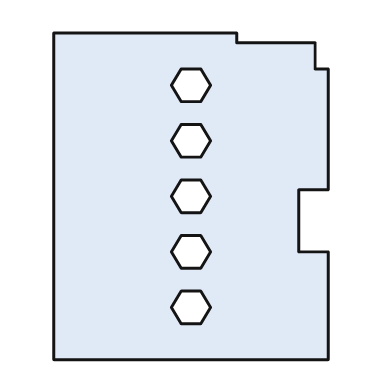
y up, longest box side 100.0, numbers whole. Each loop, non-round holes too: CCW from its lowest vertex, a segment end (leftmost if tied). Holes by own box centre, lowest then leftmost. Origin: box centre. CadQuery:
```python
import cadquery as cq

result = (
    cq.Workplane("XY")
    .moveTo(-42.0, -50.0)
    .lineTo(42.0, -50.0)
    .lineTo(42.0, -17.0)
    .lineTo(33.0, -17.0)
    .lineTo(33.0, 2.0)
    .lineTo(42.0, 2.0)
    .lineTo(42.0, 39.0)
    .lineTo(38.0, 39.0)
    .lineTo(38.0, 47.0)
    .lineTo(14.0, 47.0)
    .lineTo(14.0, 50.0)
    .lineTo(-42.0, 50.0)
    .close()
    .moveTo(-3.0, -39.0)
    .lineTo(3.0, -39.0)
    .lineTo(6.0, -34.0)
    .lineTo(3.0, -29.0)
    .lineTo(-3.0, -29.0)
    .lineTo(-6.0, -34.0)
    .close()
    .moveTo(-3.0, -22.0)
    .lineTo(3.0, -22.0)
    .lineTo(6.0, -17.0)
    .lineTo(3.0, -12.0)
    .lineTo(-3.0, -12.0)
    .lineTo(-6.0, -17.0)
    .close()
    .moveTo(-3.0, -5.0)
    .lineTo(3.0, -5.0)
    .lineTo(6.0, 0.0)
    .lineTo(3.0, 5.0)
    .lineTo(-3.0, 5.0)
    .lineTo(-6.0, 0.0)
    .close()
    .moveTo(-3.0, 12.0)
    .lineTo(3.0, 12.0)
    .lineTo(6.0, 17.0)
    .lineTo(3.0, 22.0)
    .lineTo(-3.0, 22.0)
    .lineTo(-6.0, 17.0)
    .close()
    .moveTo(-3.0, 29.0)
    .lineTo(3.0, 29.0)
    .lineTo(6.0, 34.0)
    .lineTo(3.0, 39.0)
    .lineTo(-3.0, 39.0)
    .lineTo(-6.0, 34.0)
    .close()
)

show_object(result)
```